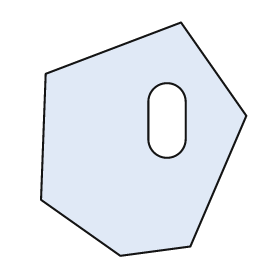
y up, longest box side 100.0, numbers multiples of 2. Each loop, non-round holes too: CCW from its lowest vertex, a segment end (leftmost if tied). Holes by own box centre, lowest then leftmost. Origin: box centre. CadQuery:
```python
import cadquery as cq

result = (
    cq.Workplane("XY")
    .moveTo(-10.0, -50.0)
    .lineTo(20.0, -46.0)
    .lineTo(44.0, 10.0)
    .lineTo(16.0, 50.0)
    .lineTo(-42.0, 28.0)
    .lineTo(-44.0, -26.0)
    .close()
    .moveTo(2.0, 0.0)
    .threePointArc((10.0, -8.0), (18.0, 0.0))
    .lineTo(18.0, 16.0)
    .threePointArc((10.0, 24.0), (2.0, 16.0))
    .close()
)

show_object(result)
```